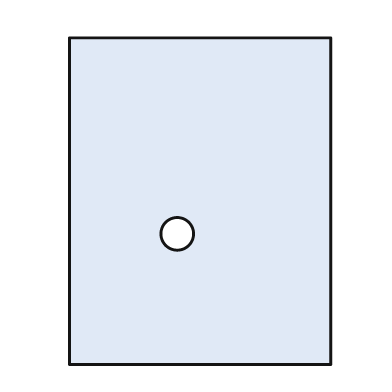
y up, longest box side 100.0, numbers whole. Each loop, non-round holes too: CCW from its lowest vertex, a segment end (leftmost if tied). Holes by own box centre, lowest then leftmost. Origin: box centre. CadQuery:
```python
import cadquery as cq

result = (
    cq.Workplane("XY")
    .moveTo(-40.0, -50.0)
    .lineTo(40.0, -50.0)
    .lineTo(40.0, 50.0)
    .lineTo(-40.0, 50.0)
    .close()
    .moveTo(-7.0, -10.0)
    .circle(5.0)
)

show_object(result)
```